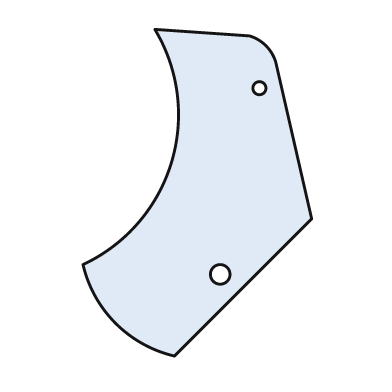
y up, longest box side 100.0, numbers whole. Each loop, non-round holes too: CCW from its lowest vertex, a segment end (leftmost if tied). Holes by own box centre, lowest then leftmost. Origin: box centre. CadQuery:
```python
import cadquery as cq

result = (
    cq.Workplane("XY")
    .moveTo(-7.0, -50.0)
    .lineTo(35.0, -8.0)
    .lineTo(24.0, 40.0)
    .threePointArc((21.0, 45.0), (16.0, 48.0))
    .lineTo(-13.0, 50.0)
    .threePointArc((-8.0, 9.0), (-35.0, -22.0))
    .threePointArc((-25.0, -40.0), (-7.0, -50.0))
    .close()
    .moveTo(7.0, -25.0)
    .circle(3.0)
    .moveTo(19.0, 32.0)
    .circle(2.0)
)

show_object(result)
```